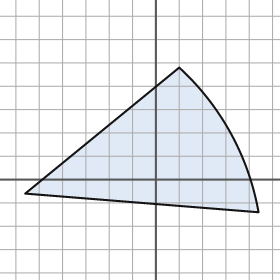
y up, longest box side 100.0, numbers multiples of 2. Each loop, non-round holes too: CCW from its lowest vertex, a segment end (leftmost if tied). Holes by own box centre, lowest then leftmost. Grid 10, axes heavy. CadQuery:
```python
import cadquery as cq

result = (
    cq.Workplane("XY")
    .moveTo(44.0, -14.0)
    .threePointArc((32.0, 20.0), (10.0, 48.0))
    .lineTo(-56.0, -6.0)
    .close()
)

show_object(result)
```